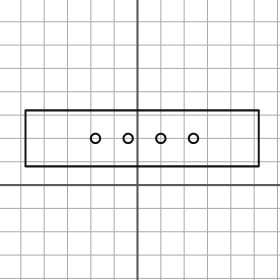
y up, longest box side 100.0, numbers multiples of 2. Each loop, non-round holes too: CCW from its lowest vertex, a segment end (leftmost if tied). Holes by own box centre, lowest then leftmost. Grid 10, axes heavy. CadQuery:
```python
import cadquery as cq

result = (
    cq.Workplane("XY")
    .moveTo(-48.0, 8.0)
    .lineTo(52.0, 8.0)
    .lineTo(52.0, 32.0)
    .lineTo(-48.0, 32.0)
    .close()
    .moveTo(-18.0, 20.0)
    .circle(2.0)
    .moveTo(-4.0, 20.0)
    .circle(2.0)
    .moveTo(10.0, 20.0)
    .circle(2.0)
    .moveTo(24.0, 20.0)
    .circle(2.0)
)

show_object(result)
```